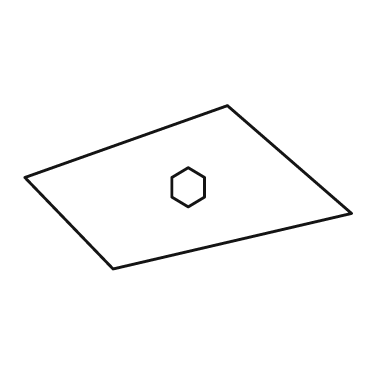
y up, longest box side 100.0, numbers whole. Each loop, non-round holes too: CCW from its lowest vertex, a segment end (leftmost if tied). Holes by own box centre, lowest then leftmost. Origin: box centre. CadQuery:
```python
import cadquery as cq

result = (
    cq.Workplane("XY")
    .moveTo(-23.0, -25.0)
    .lineTo(50.0, -8.0)
    .lineTo(12.0, 25.0)
    .lineTo(-50.0, 3.0)
    .close()
    .moveTo(0.0, -6.0)
    .lineTo(5.0, -3.0)
    .lineTo(5.0, 3.0)
    .lineTo(0.0, 6.0)
    .lineTo(-5.0, 3.0)
    .lineTo(-5.0, -3.0)
    .close()
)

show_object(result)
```